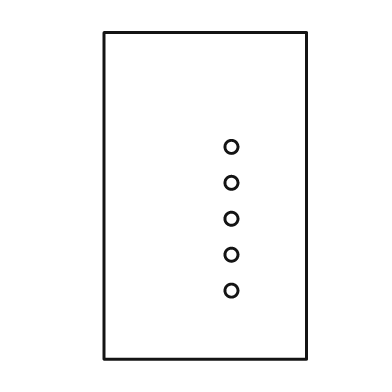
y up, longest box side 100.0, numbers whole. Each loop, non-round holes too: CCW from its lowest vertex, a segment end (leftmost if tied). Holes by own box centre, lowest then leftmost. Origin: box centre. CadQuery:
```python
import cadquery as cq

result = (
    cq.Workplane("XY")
    .moveTo(-31.0, -50.0)
    .lineTo(31.0, -50.0)
    .lineTo(31.0, 50.0)
    .lineTo(-31.0, 50.0)
    .close()
    .moveTo(8.0, -29.0)
    .circle(2.0)
    .moveTo(8.0, -18.0)
    .circle(2.0)
    .moveTo(8.0, -7.0)
    .circle(2.0)
    .moveTo(8.0, 4.0)
    .circle(2.0)
    .moveTo(8.0, 15.0)
    .circle(2.0)
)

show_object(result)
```